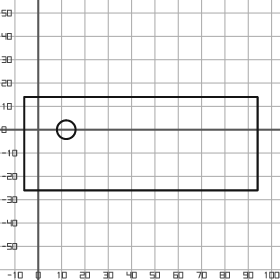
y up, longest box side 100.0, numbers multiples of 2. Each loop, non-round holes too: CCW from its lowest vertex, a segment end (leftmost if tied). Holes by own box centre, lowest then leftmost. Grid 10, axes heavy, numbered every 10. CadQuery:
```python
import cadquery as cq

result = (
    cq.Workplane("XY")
    .moveTo(-6.0, -26.0)
    .lineTo(94.0, -26.0)
    .lineTo(94.0, 14.0)
    .lineTo(-6.0, 14.0)
    .close()
    .moveTo(12.0, 0.0)
    .circle(4.0)
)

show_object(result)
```